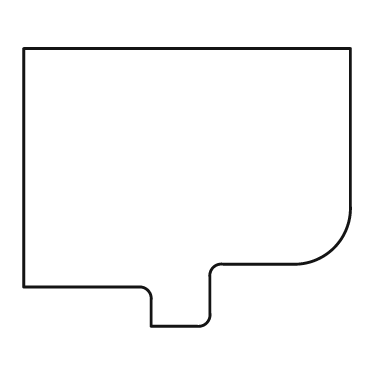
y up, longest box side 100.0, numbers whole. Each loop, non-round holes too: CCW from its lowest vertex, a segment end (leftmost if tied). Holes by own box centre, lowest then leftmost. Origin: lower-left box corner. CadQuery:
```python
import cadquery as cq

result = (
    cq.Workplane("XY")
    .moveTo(39.0, 0.0)
    .lineTo(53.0, 0.0)
    .threePointArc((56.0, 1.0), (57.0, 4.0))
    .lineTo(57.0, 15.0)
    .threePointArc((58.0, 18.0), (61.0, 19.0))
    .lineTo(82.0, 19.0)
    .threePointArc((95.0, 24.0), (100.0, 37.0))
    .lineTo(100.0, 85.0)
    .lineTo(0.0, 85.0)
    .lineTo(0.0, 12.0)
    .lineTo(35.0, 12.0)
    .threePointArc((38.0, 11.0), (39.0, 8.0))
    .close()
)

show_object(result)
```